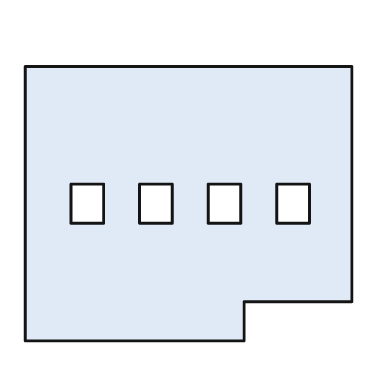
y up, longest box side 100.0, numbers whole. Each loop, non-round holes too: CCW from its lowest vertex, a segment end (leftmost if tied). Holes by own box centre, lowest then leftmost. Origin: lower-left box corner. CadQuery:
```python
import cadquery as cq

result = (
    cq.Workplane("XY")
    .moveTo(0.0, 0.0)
    .lineTo(67.0, 0.0)
    .lineTo(67.0, 12.0)
    .lineTo(100.0, 12.0)
    .lineTo(100.0, 84.0)
    .lineTo(0.0, 84.0)
    .close()
    .moveTo(14.0, 36.0)
    .lineTo(24.0, 36.0)
    .lineTo(24.0, 48.0)
    .lineTo(14.0, 48.0)
    .close()
    .moveTo(35.0, 36.0)
    .lineTo(45.0, 36.0)
    .lineTo(45.0, 48.0)
    .lineTo(35.0, 48.0)
    .close()
    .moveTo(56.0, 36.0)
    .lineTo(66.0, 36.0)
    .lineTo(66.0, 48.0)
    .lineTo(56.0, 48.0)
    .close()
    .moveTo(77.0, 36.0)
    .lineTo(87.0, 36.0)
    .lineTo(87.0, 48.0)
    .lineTo(77.0, 48.0)
    .close()
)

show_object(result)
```